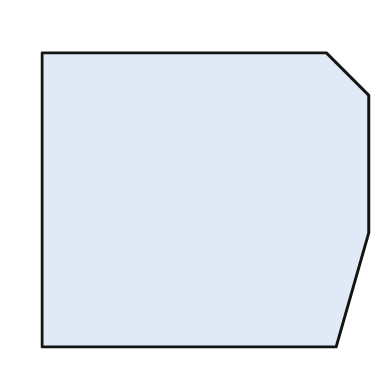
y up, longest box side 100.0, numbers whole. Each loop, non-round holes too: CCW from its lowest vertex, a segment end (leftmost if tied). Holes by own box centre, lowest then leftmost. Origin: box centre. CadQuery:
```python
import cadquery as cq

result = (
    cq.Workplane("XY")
    .moveTo(-50.0, -45.0)
    .lineTo(40.0, -45.0)
    .lineTo(50.0, -10.0)
    .lineTo(50.0, 32.0)
    .lineTo(37.0, 45.0)
    .lineTo(-50.0, 45.0)
    .close()
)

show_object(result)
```